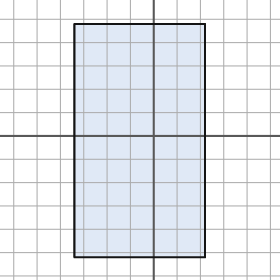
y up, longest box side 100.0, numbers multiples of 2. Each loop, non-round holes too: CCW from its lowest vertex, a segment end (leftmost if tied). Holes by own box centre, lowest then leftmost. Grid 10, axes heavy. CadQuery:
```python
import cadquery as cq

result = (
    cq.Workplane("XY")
    .moveTo(-34.0, -52.0)
    .lineTo(22.0, -52.0)
    .lineTo(22.0, 48.0)
    .lineTo(-34.0, 48.0)
    .close()
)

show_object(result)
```